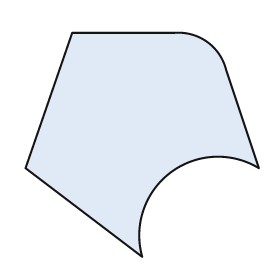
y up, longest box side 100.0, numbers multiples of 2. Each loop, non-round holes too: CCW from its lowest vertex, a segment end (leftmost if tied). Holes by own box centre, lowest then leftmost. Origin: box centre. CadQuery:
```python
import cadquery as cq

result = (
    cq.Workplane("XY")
    .moveTo(0.0, -48.0)
    .threePointArc((12.0, -12.0), (50.0, -10.0))
    .lineTo(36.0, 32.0)
    .threePointArc((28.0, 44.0), (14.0, 48.0))
    .lineTo(-30.0, 48.0)
    .lineTo(-50.0, -10.0)
    .close()
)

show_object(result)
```